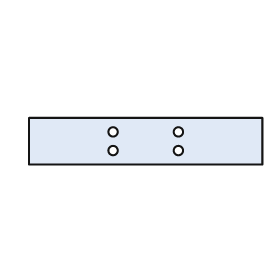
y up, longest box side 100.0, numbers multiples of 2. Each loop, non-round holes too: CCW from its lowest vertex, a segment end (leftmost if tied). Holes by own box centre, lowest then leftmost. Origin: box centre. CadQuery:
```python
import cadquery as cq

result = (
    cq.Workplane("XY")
    .moveTo(-50.0, -10.0)
    .lineTo(50.0, -10.0)
    .lineTo(50.0, 10.0)
    .lineTo(-50.0, 10.0)
    .close()
    .moveTo(-14.0, -4.0)
    .circle(2.0)
    .moveTo(14.0, -4.0)
    .circle(2.0)
    .moveTo(-14.0, 4.0)
    .circle(2.0)
    .moveTo(14.0, 4.0)
    .circle(2.0)
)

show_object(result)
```